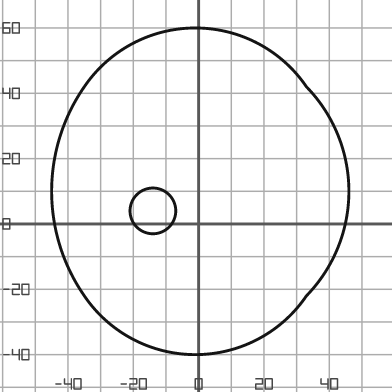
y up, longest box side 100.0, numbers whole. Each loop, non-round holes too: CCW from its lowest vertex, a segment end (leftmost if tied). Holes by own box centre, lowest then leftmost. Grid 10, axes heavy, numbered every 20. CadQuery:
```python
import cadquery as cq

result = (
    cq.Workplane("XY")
    .moveTo(-35.0, -22.0)
    .threePointArc((-1.0, -40.0), (33.0, -22.0))
    .threePointArc((46.0, 10.0), (33.0, 42.0))
    .threePointArc((-1.0, 60.0), (-35.0, 42.0))
    .threePointArc((-45.0, 10.0), (-35.0, -22.0))
    .close()
    .moveTo(-14.0, 4.0)
    .circle(7.0)
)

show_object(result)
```